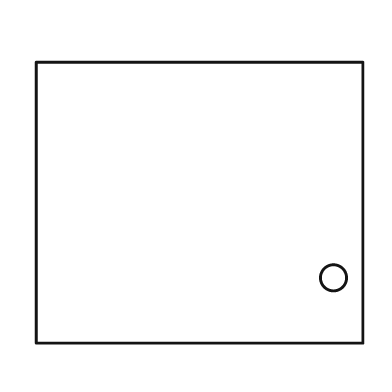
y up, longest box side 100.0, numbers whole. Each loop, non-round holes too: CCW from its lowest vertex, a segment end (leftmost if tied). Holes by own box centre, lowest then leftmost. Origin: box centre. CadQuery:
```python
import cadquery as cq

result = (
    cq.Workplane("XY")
    .moveTo(-50.0, -43.0)
    .lineTo(50.0, -43.0)
    .lineTo(50.0, 43.0)
    .lineTo(-50.0, 43.0)
    .close()
    .moveTo(41.0, -23.0)
    .circle(4.0)
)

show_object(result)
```